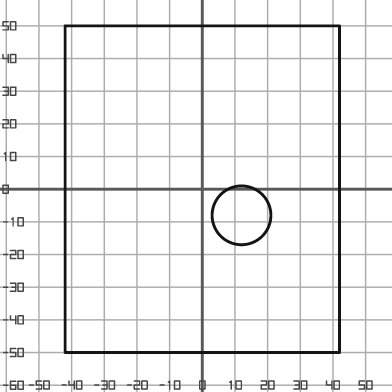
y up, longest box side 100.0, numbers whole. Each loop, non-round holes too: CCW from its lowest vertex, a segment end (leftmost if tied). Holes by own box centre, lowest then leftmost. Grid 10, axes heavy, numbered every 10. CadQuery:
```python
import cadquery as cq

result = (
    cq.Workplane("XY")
    .moveTo(-42.0, -50.0)
    .lineTo(42.0, -50.0)
    .lineTo(42.0, 50.0)
    .lineTo(-42.0, 50.0)
    .close()
    .moveTo(12.0, -8.0)
    .circle(9.0)
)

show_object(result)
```